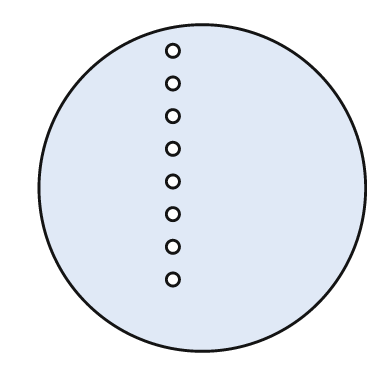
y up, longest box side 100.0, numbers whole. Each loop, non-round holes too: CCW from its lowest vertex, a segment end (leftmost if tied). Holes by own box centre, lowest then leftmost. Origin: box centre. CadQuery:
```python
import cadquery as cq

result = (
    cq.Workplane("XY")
    .moveTo(0.0, 0.0)
    .circle(50.0)
    .moveTo(-9.0, -28.0)
    .circle(2.0)
    .moveTo(-9.0, -18.0)
    .circle(2.0)
    .moveTo(-9.0, -8.0)
    .circle(2.0)
    .moveTo(-9.0, 2.0)
    .circle(2.0)
    .moveTo(-9.0, 12.0)
    .circle(2.0)
    .moveTo(-9.0, 22.0)
    .circle(2.0)
    .moveTo(-9.0, 32.0)
    .circle(2.0)
    .moveTo(-9.0, 42.0)
    .circle(2.0)
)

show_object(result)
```